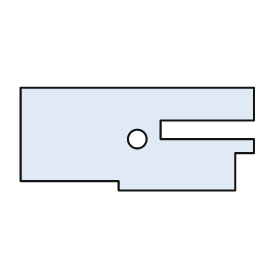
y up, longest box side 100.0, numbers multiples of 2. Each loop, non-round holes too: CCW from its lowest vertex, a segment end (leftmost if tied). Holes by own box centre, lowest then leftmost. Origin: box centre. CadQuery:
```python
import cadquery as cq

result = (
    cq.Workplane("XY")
    .moveTo(-8.0, -22.0)
    .lineTo(42.0, -22.0)
    .lineTo(42.0, -6.0)
    .lineTo(50.0, -6.0)
    .lineTo(50.0, 0.0)
    .lineTo(10.0, 0.0)
    .lineTo(10.0, 8.0)
    .lineTo(50.0, 8.0)
    .lineTo(50.0, 22.0)
    .lineTo(-50.0, 22.0)
    .lineTo(-50.0, -18.0)
    .lineTo(-8.0, -18.0)
    .close()
    .moveTo(0.0, 0.0)
    .circle(4.0)
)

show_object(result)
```